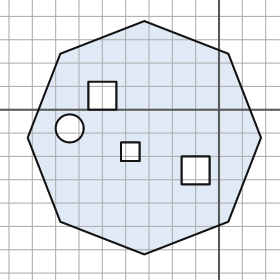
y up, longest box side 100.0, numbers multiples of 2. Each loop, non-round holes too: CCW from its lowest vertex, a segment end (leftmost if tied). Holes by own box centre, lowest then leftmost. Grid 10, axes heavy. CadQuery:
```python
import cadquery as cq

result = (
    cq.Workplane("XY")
    .moveTo(-32.0, -62.0)
    .lineTo(4.0, -48.0)
    .lineTo(18.0, -12.0)
    .lineTo(4.0, 24.0)
    .lineTo(-32.0, 38.0)
    .lineTo(-68.0, 24.0)
    .lineTo(-82.0, -12.0)
    .lineTo(-68.0, -48.0)
    .close()
    .moveTo(-16.0, -32.0)
    .lineTo(-4.0, -32.0)
    .lineTo(-4.0, -20.0)
    .lineTo(-16.0, -20.0)
    .close()
    .moveTo(-42.0, -22.0)
    .lineTo(-34.0, -22.0)
    .lineTo(-34.0, -14.0)
    .lineTo(-42.0, -14.0)
    .close()
    .moveTo(-64.0, -8.0)
    .circle(6.0)
    .moveTo(-56.0, 0.0)
    .lineTo(-44.0, 0.0)
    .lineTo(-44.0, 12.0)
    .lineTo(-56.0, 12.0)
    .close()
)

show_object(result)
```